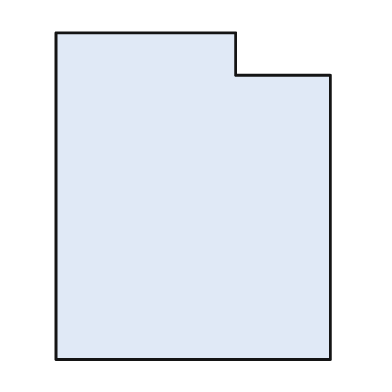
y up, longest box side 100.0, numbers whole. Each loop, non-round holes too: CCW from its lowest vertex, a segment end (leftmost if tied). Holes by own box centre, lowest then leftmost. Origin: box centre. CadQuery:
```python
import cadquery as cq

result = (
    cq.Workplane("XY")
    .moveTo(-42.0, -50.0)
    .lineTo(42.0, -50.0)
    .lineTo(42.0, 37.0)
    .lineTo(13.0, 37.0)
    .lineTo(13.0, 50.0)
    .lineTo(-42.0, 50.0)
    .close()
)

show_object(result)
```